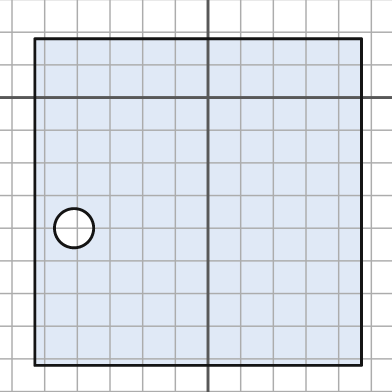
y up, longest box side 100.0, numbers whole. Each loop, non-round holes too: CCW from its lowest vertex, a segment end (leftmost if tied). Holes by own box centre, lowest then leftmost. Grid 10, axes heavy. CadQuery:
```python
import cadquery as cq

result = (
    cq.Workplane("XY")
    .moveTo(-53.0, -82.0)
    .lineTo(47.0, -82.0)
    .lineTo(47.0, 18.0)
    .lineTo(-53.0, 18.0)
    .close()
    .moveTo(-41.0, -40.0)
    .circle(6.0)
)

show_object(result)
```